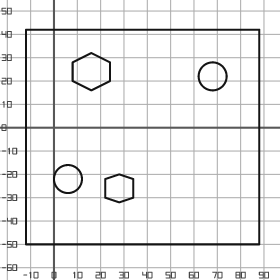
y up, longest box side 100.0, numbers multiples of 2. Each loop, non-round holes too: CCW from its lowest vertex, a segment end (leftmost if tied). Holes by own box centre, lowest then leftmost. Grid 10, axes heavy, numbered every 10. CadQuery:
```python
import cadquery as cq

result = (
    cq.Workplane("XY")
    .moveTo(-12.0, -50.0)
    .lineTo(88.0, -50.0)
    .lineTo(88.0, 42.0)
    .lineTo(-12.0, 42.0)
    .close()
    .moveTo(28.0, -32.0)
    .lineTo(34.0, -30.0)
    .lineTo(34.0, -22.0)
    .lineTo(28.0, -20.0)
    .lineTo(22.0, -22.0)
    .lineTo(22.0, -30.0)
    .close()
    .moveTo(6.0, -22.0)
    .circle(6.0)
    .moveTo(68.0, 22.0)
    .circle(6.0)
    .moveTo(16.0, 16.0)
    .lineTo(24.0, 20.0)
    .lineTo(24.0, 28.0)
    .lineTo(16.0, 32.0)
    .lineTo(8.0, 28.0)
    .lineTo(8.0, 20.0)
    .close()
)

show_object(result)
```